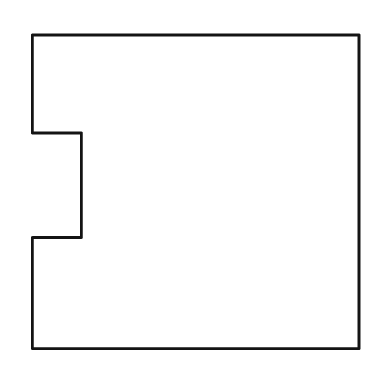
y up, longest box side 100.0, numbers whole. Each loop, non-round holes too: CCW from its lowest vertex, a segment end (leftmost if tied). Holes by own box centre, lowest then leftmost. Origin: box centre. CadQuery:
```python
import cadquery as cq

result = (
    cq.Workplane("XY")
    .moveTo(-50.0, -48.0)
    .lineTo(50.0, -48.0)
    .lineTo(50.0, 48.0)
    .lineTo(-50.0, 48.0)
    .lineTo(-50.0, 18.0)
    .lineTo(-35.0, 18.0)
    .lineTo(-35.0, -14.0)
    .lineTo(-50.0, -14.0)
    .close()
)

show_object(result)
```